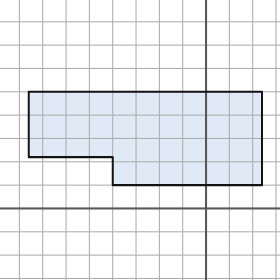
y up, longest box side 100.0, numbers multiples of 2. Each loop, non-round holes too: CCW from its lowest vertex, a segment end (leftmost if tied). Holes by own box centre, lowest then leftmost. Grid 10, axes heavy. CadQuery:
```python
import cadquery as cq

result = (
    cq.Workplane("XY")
    .moveTo(-40.0, 10.0)
    .lineTo(24.0, 10.0)
    .lineTo(24.0, 50.0)
    .lineTo(-76.0, 50.0)
    .lineTo(-76.0, 22.0)
    .lineTo(-40.0, 22.0)
    .close()
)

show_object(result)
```